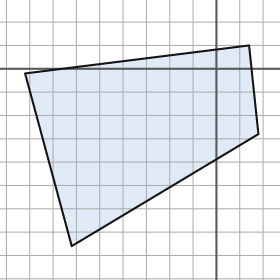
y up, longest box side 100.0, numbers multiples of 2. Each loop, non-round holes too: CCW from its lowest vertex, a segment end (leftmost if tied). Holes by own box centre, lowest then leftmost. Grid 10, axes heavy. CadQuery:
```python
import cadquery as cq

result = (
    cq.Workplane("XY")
    .moveTo(-62.0, -76.0)
    .lineTo(18.0, -28.0)
    .lineTo(14.0, 10.0)
    .lineTo(-82.0, -2.0)
    .close()
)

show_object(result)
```